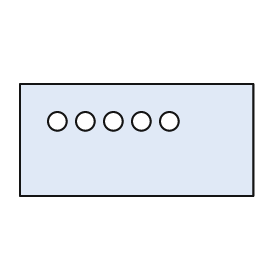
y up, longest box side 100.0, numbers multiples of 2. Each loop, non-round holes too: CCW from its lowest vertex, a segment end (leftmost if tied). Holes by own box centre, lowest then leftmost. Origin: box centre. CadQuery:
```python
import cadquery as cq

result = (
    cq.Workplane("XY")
    .moveTo(-50.0, -24.0)
    .lineTo(50.0, -24.0)
    .lineTo(50.0, 24.0)
    .lineTo(-50.0, 24.0)
    .close()
    .moveTo(-34.0, 8.0)
    .circle(4.0)
    .moveTo(-22.0, 8.0)
    .circle(4.0)
    .moveTo(-10.0, 8.0)
    .circle(4.0)
    .moveTo(2.0, 8.0)
    .circle(4.0)
    .moveTo(14.0, 8.0)
    .circle(4.0)
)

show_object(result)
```